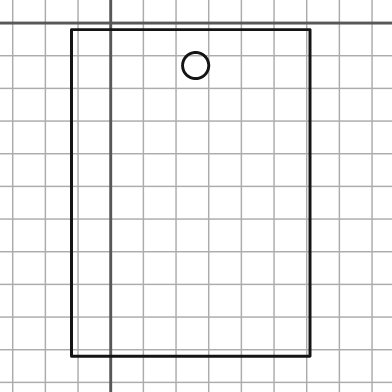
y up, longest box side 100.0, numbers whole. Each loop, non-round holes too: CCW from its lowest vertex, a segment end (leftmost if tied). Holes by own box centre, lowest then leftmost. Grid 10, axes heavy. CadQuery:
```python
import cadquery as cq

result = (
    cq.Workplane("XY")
    .moveTo(-12.0, -102.0)
    .lineTo(61.0, -102.0)
    .lineTo(61.0, -2.0)
    .lineTo(-12.0, -2.0)
    .close()
    .moveTo(26.0, -13.0)
    .circle(4.0)
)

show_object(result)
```